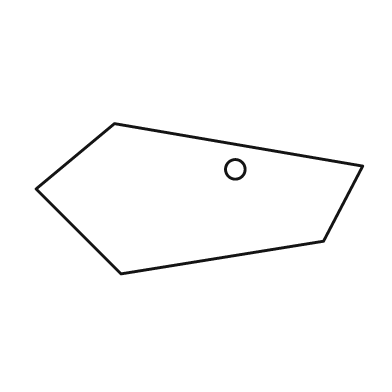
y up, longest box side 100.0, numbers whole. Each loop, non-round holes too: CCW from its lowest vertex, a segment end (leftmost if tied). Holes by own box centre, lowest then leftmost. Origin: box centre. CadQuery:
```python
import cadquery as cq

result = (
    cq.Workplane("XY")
    .moveTo(-24.0, -23.0)
    .lineTo(38.0, -13.0)
    .lineTo(50.0, 10.0)
    .lineTo(-26.0, 23.0)
    .lineTo(-50.0, 3.0)
    .close()
    .moveTo(11.0, 9.0)
    .circle(3.0)
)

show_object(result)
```